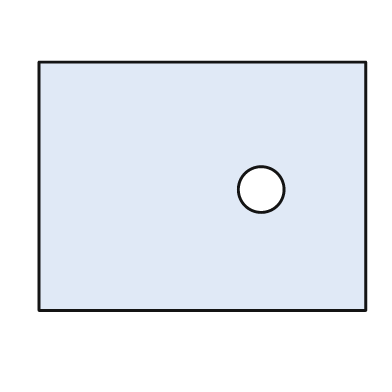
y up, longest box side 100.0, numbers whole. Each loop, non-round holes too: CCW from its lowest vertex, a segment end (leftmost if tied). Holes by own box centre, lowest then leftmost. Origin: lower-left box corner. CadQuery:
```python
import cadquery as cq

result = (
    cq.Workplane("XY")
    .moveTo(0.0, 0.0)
    .lineTo(100.0, 0.0)
    .lineTo(100.0, 76.0)
    .lineTo(0.0, 76.0)
    .close()
    .moveTo(68.0, 37.0)
    .circle(7.0)
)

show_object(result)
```